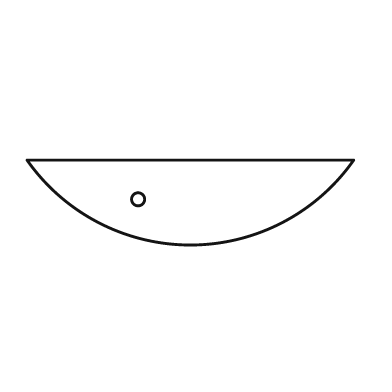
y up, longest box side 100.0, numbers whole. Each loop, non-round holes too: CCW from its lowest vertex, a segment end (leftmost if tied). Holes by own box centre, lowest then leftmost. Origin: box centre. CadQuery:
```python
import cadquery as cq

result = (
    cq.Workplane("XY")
    .moveTo(-50.0, 13.0)
    .threePointArc((0.0, -13.0), (50.0, 13.0))
    .close()
    .moveTo(-16.0, 1.0)
    .circle(2.0)
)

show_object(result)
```